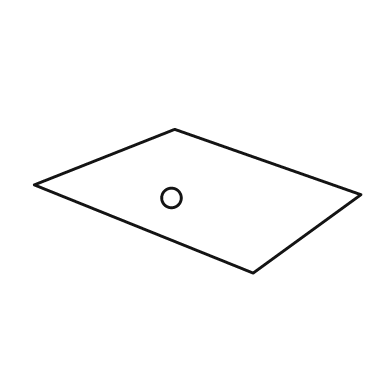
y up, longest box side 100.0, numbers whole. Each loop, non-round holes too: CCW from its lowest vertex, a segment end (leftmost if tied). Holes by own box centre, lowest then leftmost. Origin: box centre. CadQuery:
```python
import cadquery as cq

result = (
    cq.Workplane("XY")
    .moveTo(17.0, -22.0)
    .lineTo(50.0, 2.0)
    .lineTo(-7.0, 22.0)
    .lineTo(-50.0, 5.0)
    .close()
    .moveTo(-8.0, 1.0)
    .circle(3.0)
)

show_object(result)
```